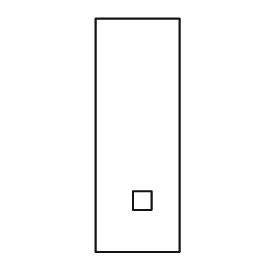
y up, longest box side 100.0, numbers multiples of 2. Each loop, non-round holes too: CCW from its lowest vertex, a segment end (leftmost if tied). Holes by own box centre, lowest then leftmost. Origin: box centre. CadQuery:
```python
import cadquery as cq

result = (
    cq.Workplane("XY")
    .moveTo(-18.0, -50.0)
    .lineTo(18.0, -50.0)
    .lineTo(18.0, 50.0)
    .lineTo(-18.0, 50.0)
    .close()
    .moveTo(-2.0, -32.0)
    .lineTo(6.0, -32.0)
    .lineTo(6.0, -24.0)
    .lineTo(-2.0, -24.0)
    .close()
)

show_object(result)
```